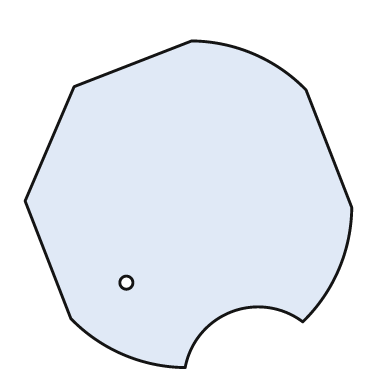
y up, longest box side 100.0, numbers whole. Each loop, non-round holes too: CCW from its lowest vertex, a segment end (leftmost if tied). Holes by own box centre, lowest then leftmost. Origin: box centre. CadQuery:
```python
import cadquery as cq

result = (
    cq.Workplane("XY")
    .moveTo(-1.0, -50.0)
    .threePointArc((13.0, -33.0), (35.0, -36.0))
    .threePointArc((46.0, -20.0), (50.0, -1.0))
    .lineTo(36.0, 35.0)
    .threePointArc((20.0, 46.0), (1.0, 50.0))
    .lineTo(-35.0, 36.0)
    .lineTo(-50.0, 1.0)
    .lineTo(-36.0, -35.0)
    .threePointArc((-20.0, -46.0), (-1.0, -50.0))
    .close()
    .moveTo(-19.0, -24.0)
    .circle(2.0)
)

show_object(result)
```